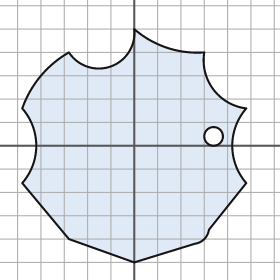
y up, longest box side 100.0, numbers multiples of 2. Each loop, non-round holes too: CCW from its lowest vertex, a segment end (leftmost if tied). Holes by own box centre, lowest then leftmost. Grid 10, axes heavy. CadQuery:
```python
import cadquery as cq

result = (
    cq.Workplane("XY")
    .moveTo(0.0, -50.0)
    .lineTo(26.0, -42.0)
    .threePointArc((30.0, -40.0), (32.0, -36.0))
    .lineTo(48.0, -16.0)
    .threePointArc((42.0, 0.0), (48.0, 16.0))
    .threePointArc((34.0, 24.0), (30.0, 40.0))
    .threePointArc((14.0, 42.0), (0.0, 50.0))
    .threePointArc((-10.0, 34.0), (-28.0, 40.0))
    .threePointArc((-40.0, 30.0), (-48.0, 16.0))
    .threePointArc((-42.0, 0.0), (-48.0, -16.0))
    .lineTo(-28.0, -40.0)
    .close()
    .moveTo(34.0, 4.0)
    .circle(4.0)
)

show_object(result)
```